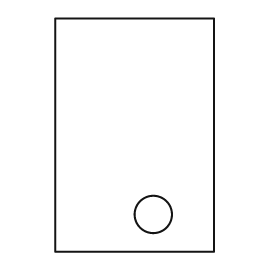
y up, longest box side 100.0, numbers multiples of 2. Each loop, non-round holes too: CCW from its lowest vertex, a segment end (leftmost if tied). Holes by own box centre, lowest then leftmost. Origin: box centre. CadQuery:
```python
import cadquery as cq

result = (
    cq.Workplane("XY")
    .moveTo(-34.0, -50.0)
    .lineTo(34.0, -50.0)
    .lineTo(34.0, 50.0)
    .lineTo(-34.0, 50.0)
    .close()
    .moveTo(8.0, -34.0)
    .circle(8.0)
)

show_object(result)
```